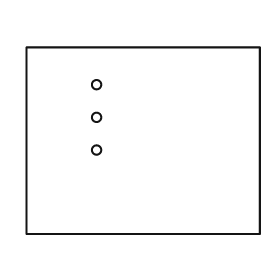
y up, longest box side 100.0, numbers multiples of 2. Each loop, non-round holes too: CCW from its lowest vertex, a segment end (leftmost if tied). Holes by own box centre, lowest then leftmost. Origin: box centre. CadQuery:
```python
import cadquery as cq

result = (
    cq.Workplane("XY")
    .moveTo(-50.0, -40.0)
    .lineTo(50.0, -40.0)
    .lineTo(50.0, 40.0)
    .lineTo(-50.0, 40.0)
    .close()
    .moveTo(-20.0, -4.0)
    .circle(2.0)
    .moveTo(-20.0, 10.0)
    .circle(2.0)
    .moveTo(-20.0, 24.0)
    .circle(2.0)
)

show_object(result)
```